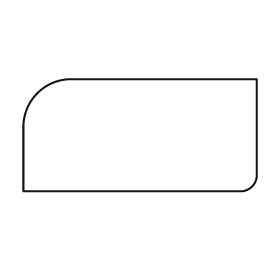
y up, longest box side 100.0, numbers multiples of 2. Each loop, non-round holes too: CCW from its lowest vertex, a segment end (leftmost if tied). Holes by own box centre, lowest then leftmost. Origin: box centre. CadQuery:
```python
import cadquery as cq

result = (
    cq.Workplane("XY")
    .moveTo(-50.0, -24.0)
    .lineTo(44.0, -24.0)
    .threePointArc((48.0, -22.0), (50.0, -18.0))
    .lineTo(50.0, 24.0)
    .lineTo(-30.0, 24.0)
    .threePointArc((-44.0, 18.0), (-50.0, 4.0))
    .close()
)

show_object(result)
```